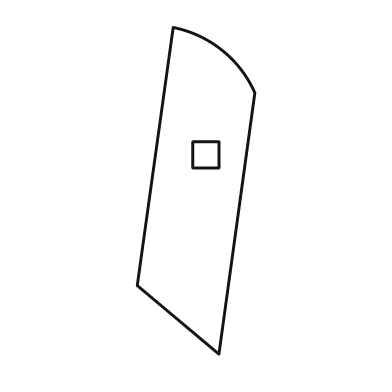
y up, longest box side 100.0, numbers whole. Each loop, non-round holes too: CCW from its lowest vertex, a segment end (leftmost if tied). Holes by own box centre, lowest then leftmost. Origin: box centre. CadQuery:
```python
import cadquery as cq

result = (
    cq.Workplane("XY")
    .moveTo(7.0, -50.0)
    .lineTo(18.0, 30.0)
    .threePointArc((8.0, 43.0), (-7.0, 50.0))
    .lineTo(-18.0, -29.0)
    .close()
    .moveTo(-1.0, 7.0)
    .lineTo(7.0, 7.0)
    .lineTo(7.0, 15.0)
    .lineTo(-1.0, 15.0)
    .close()
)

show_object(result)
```